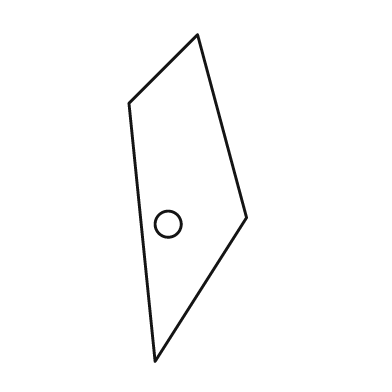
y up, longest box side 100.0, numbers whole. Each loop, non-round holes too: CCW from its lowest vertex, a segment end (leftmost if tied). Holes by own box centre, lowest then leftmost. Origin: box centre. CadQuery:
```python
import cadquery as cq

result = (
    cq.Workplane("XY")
    .moveTo(-10.0, -50.0)
    .lineTo(18.0, -6.0)
    .lineTo(3.0, 50.0)
    .lineTo(-18.0, 29.0)
    .close()
    .moveTo(-6.0, -8.0)
    .circle(4.0)
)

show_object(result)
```